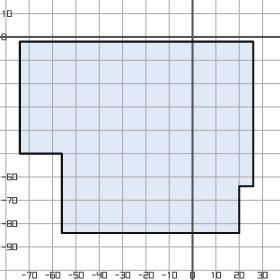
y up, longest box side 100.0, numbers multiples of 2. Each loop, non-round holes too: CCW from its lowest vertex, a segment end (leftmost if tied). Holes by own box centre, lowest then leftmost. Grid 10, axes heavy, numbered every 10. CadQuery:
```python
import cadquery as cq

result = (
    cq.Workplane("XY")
    .moveTo(-56.0, -84.0)
    .lineTo(20.0, -84.0)
    .lineTo(20.0, -64.0)
    .lineTo(26.0, -64.0)
    .lineTo(26.0, -2.0)
    .lineTo(-74.0, -2.0)
    .lineTo(-74.0, -50.0)
    .lineTo(-56.0, -50.0)
    .close()
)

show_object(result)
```